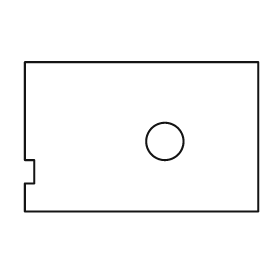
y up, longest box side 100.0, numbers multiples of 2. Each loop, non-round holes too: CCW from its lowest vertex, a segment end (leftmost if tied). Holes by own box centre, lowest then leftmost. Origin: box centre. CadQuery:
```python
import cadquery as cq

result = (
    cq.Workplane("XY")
    .moveTo(-50.0, -32.0)
    .lineTo(50.0, -32.0)
    .lineTo(50.0, 32.0)
    .lineTo(-50.0, 32.0)
    .lineTo(-50.0, -10.0)
    .lineTo(-46.0, -10.0)
    .lineTo(-46.0, -20.0)
    .lineTo(-50.0, -20.0)
    .close()
    .moveTo(10.0, -2.0)
    .circle(8.0)
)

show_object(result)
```